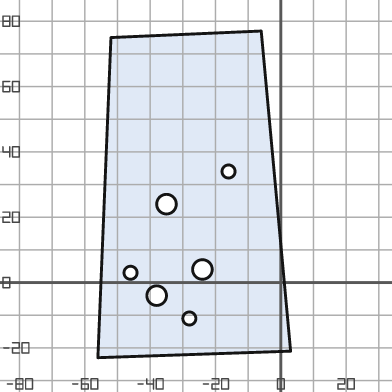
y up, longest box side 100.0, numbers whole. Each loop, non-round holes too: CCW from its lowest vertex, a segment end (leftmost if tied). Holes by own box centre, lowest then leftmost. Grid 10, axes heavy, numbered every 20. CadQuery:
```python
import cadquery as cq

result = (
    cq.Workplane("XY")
    .moveTo(-56.0, -23.0)
    .lineTo(3.0, -21.0)
    .lineTo(-6.0, 77.0)
    .lineTo(-52.0, 75.0)
    .close()
    .moveTo(-28.0, -11.0)
    .circle(2.0)
    .moveTo(-38.0, -4.0)
    .circle(3.0)
    .moveTo(-46.0, 3.0)
    .circle(2.0)
    .moveTo(-24.0, 4.0)
    .circle(3.0)
    .moveTo(-35.0, 24.0)
    .circle(3.0)
    .moveTo(-16.0, 34.0)
    .circle(2.0)
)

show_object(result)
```